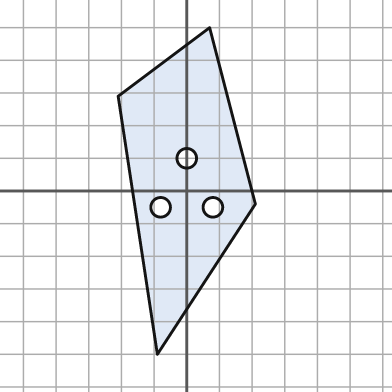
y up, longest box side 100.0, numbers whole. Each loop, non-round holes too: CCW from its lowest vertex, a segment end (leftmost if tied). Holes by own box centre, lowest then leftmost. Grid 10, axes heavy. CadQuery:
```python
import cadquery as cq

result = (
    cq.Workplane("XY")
    .moveTo(-9.0, -50.0)
    .lineTo(21.0, -4.0)
    .lineTo(7.0, 50.0)
    .lineTo(-21.0, 29.0)
    .close()
    .moveTo(-8.0, -5.0)
    .circle(3.0)
    .moveTo(8.0, -5.0)
    .circle(3.0)
    .moveTo(0.0, 10.0)
    .circle(3.0)
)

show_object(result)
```